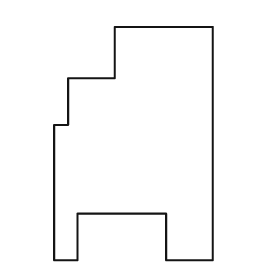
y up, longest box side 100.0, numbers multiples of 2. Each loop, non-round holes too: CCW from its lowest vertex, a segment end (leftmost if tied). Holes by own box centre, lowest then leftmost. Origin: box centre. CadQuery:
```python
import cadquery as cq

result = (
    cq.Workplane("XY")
    .moveTo(-34.0, -50.0)
    .lineTo(-24.0, -50.0)
    .lineTo(-24.0, -30.0)
    .lineTo(14.0, -30.0)
    .lineTo(14.0, -50.0)
    .lineTo(34.0, -50.0)
    .lineTo(34.0, 50.0)
    .lineTo(-8.0, 50.0)
    .lineTo(-8.0, 28.0)
    .lineTo(-28.0, 28.0)
    .lineTo(-28.0, 8.0)
    .lineTo(-34.0, 8.0)
    .close()
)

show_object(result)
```